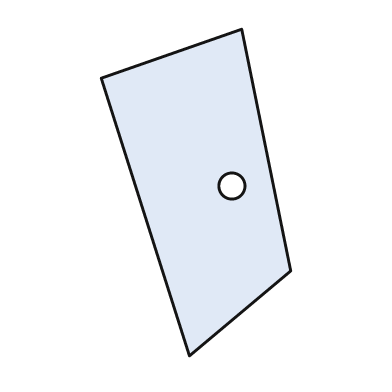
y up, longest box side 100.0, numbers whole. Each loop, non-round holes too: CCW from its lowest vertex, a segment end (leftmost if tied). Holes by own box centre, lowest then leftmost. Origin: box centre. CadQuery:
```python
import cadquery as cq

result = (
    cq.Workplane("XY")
    .moveTo(-2.0, -50.0)
    .lineTo(29.0, -24.0)
    .lineTo(14.0, 50.0)
    .lineTo(-29.0, 35.0)
    .close()
    .moveTo(11.0, 2.0)
    .circle(4.0)
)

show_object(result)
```